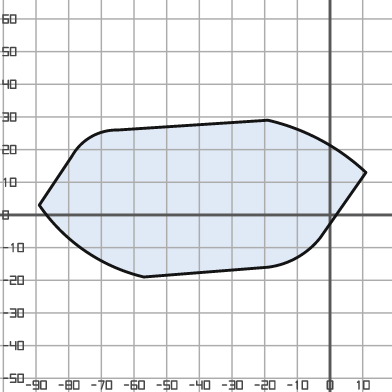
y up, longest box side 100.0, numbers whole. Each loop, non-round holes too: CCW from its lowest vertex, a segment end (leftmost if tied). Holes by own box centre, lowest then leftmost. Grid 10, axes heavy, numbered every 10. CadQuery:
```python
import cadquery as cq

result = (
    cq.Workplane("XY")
    .moveTo(-57.0, -19.0)
    .lineTo(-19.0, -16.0)
    .threePointArc((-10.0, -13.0), (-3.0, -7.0))
    .lineTo(11.0, 13.0)
    .threePointArc((-3.0, 23.0), (-19.0, 29.0))
    .lineTo(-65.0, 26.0)
    .threePointArc((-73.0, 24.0), (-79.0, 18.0))
    .lineTo(-89.0, 3.0)
    .threePointArc((-75.0, -11.0), (-57.0, -19.0))
    .close()
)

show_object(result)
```